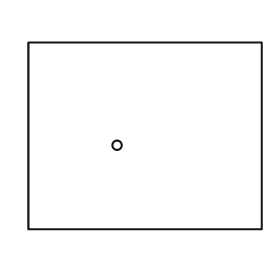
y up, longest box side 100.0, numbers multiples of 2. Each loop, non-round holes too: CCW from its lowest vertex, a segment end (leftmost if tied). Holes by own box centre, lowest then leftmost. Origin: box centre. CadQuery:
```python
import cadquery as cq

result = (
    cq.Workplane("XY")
    .moveTo(-50.0, -40.0)
    .lineTo(50.0, -40.0)
    .lineTo(50.0, 40.0)
    .lineTo(-50.0, 40.0)
    .close()
    .moveTo(-12.0, -4.0)
    .circle(2.0)
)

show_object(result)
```